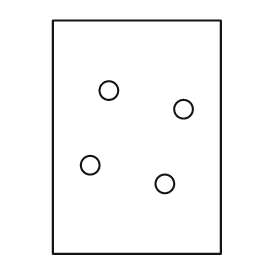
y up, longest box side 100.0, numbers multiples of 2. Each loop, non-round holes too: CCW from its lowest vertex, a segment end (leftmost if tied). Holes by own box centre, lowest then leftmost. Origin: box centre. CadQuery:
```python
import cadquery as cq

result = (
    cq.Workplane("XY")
    .moveTo(-36.0, -50.0)
    .lineTo(36.0, -50.0)
    .lineTo(36.0, 50.0)
    .lineTo(-36.0, 50.0)
    .close()
    .moveTo(12.0, -20.0)
    .circle(4.0)
    .moveTo(-20.0, -12.0)
    .circle(4.0)
    .moveTo(20.0, 12.0)
    .circle(4.0)
    .moveTo(-12.0, 20.0)
    .circle(4.0)
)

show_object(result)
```